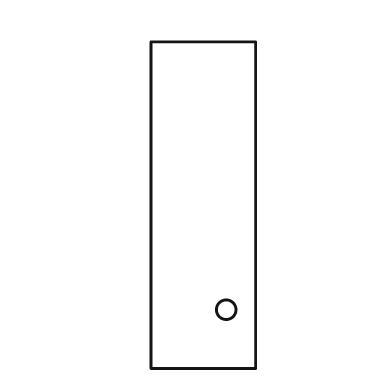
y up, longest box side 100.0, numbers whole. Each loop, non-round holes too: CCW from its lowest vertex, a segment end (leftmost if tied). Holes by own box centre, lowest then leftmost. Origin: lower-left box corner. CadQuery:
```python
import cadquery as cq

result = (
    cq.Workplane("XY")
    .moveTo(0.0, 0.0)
    .lineTo(32.0, 0.0)
    .lineTo(32.0, 100.0)
    .lineTo(0.0, 100.0)
    .close()
    .moveTo(23.0, 18.0)
    .circle(3.0)
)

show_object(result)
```